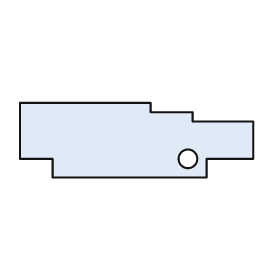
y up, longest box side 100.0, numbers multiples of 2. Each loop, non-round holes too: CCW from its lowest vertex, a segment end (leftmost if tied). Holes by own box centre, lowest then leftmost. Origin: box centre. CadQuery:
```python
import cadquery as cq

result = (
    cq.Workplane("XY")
    .moveTo(-36.0, -16.0)
    .lineTo(30.0, -16.0)
    .lineTo(30.0, -8.0)
    .lineTo(50.0, -8.0)
    .lineTo(50.0, 8.0)
    .lineTo(24.0, 8.0)
    .lineTo(24.0, 12.0)
    .lineTo(6.0, 12.0)
    .lineTo(6.0, 16.0)
    .lineTo(-50.0, 16.0)
    .lineTo(-50.0, -8.0)
    .lineTo(-36.0, -8.0)
    .close()
    .moveTo(22.0, -8.0)
    .circle(4.0)
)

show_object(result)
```